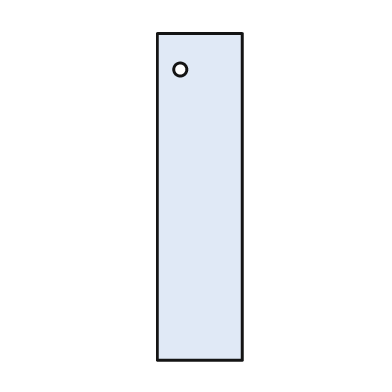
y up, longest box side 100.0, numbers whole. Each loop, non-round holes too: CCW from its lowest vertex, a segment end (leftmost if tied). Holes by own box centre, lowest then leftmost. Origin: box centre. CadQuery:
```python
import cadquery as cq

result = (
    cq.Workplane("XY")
    .moveTo(-13.0, -50.0)
    .lineTo(13.0, -50.0)
    .lineTo(13.0, 50.0)
    .lineTo(-13.0, 50.0)
    .close()
    .moveTo(-6.0, 39.0)
    .circle(2.0)
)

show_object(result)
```